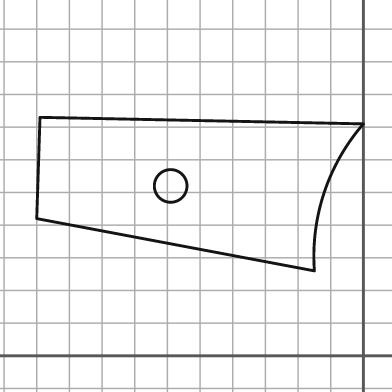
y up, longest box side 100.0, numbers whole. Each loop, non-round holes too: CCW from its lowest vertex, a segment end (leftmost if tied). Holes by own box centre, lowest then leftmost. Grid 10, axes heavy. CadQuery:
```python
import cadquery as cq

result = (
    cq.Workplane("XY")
    .moveTo(-15.0, 26.0)
    .threePointArc((-12.0, 50.0), (0.0, 71.0))
    .lineTo(-99.0, 73.0)
    .lineTo(-100.0, 42.0)
    .close()
    .moveTo(-59.0, 52.0)
    .circle(5.0)
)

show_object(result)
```